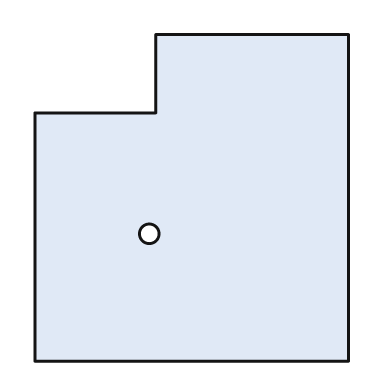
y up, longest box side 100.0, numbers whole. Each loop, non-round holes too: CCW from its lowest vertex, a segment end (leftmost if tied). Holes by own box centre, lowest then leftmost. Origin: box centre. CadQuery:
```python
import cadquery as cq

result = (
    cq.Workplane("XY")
    .moveTo(-48.0, -50.0)
    .lineTo(48.0, -50.0)
    .lineTo(48.0, 50.0)
    .lineTo(-11.0, 50.0)
    .lineTo(-11.0, 26.0)
    .lineTo(-48.0, 26.0)
    .close()
    .moveTo(-13.0, -11.0)
    .circle(3.0)
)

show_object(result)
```